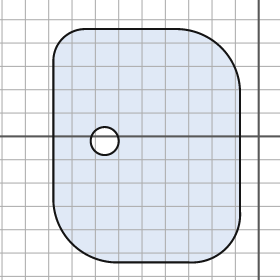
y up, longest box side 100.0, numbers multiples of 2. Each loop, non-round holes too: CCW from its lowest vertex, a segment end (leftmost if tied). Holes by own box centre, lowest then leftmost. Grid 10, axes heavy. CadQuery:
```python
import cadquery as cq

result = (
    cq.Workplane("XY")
    .moveTo(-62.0, -54.0)
    .lineTo(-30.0, -54.0)
    .threePointArc((-14.0, -48.0), (-8.0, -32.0))
    .lineTo(-8.0, 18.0)
    .threePointArc((-16.0, 38.0), (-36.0, 46.0))
    .lineTo(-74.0, 46.0)
    .threePointArc((-84.0, 42.0), (-88.0, 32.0))
    .lineTo(-88.0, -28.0)
    .threePointArc((-80.0, -46.0), (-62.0, -54.0))
    .close()
    .moveTo(-66.0, -2.0)
    .circle(6.0)
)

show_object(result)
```